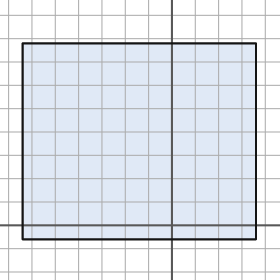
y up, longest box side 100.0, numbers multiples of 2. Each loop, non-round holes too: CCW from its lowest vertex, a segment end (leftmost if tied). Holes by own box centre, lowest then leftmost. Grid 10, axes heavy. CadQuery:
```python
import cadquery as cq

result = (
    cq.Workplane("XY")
    .moveTo(-64.0, -6.0)
    .lineTo(36.0, -6.0)
    .lineTo(36.0, 78.0)
    .lineTo(-64.0, 78.0)
    .close()
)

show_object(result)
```